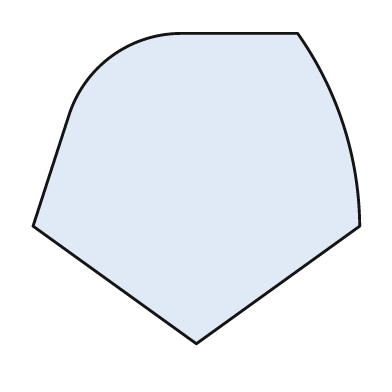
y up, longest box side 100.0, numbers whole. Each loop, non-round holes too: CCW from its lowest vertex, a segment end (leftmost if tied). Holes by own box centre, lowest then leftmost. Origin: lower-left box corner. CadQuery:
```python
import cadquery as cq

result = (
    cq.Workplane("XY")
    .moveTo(50.0, 0.0)
    .lineTo(100.0, 36.0)
    .threePointArc((95.0, 67.0), (81.0, 95.0))
    .lineTo(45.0, 95.0)
    .threePointArc((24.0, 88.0), (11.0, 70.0))
    .lineTo(0.0, 36.0)
    .close()
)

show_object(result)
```